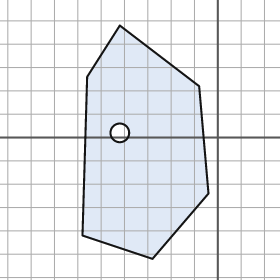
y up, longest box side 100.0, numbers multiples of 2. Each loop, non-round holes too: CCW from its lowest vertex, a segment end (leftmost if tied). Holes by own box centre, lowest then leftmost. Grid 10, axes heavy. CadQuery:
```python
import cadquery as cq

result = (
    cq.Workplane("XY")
    .moveTo(-28.0, -52.0)
    .lineTo(-4.0, -24.0)
    .lineTo(-8.0, 22.0)
    .lineTo(-42.0, 48.0)
    .lineTo(-56.0, 26.0)
    .lineTo(-58.0, -42.0)
    .close()
    .moveTo(-42.0, 2.0)
    .circle(4.0)
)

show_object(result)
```